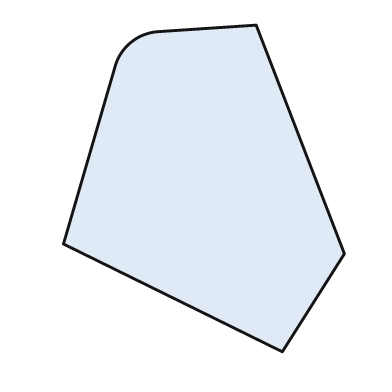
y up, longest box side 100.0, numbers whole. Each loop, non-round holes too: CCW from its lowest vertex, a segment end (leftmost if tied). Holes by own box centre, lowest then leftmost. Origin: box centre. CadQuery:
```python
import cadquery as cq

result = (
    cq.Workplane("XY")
    .moveTo(24.0, -50.0)
    .lineTo(43.0, -20.0)
    .lineTo(16.0, 50.0)
    .lineTo(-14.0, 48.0)
    .threePointArc((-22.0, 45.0), (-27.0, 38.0))
    .lineTo(-43.0, -17.0)
    .close()
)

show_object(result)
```